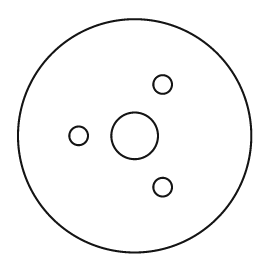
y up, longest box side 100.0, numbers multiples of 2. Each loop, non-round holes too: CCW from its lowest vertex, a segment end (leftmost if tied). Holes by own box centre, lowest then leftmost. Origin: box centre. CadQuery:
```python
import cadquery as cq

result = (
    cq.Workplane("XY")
    .moveTo(0.0, 0.0)
    .circle(50.0)
    .moveTo(12.0, -22.0)
    .circle(4.0)
    .moveTo(-24.0, 0.0)
    .circle(4.0)
    .moveTo(0.0, 0.0)
    .circle(10.0)
    .moveTo(12.0, 22.0)
    .circle(4.0)
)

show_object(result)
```